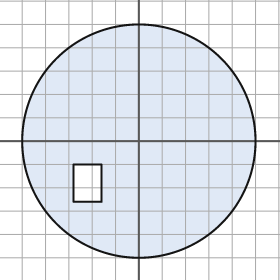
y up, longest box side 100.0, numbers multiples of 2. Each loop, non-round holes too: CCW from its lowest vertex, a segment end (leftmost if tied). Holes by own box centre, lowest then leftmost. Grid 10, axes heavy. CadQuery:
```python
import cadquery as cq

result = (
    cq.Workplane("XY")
    .moveTo(0.0, 0.0)
    .circle(50.0)
    .moveTo(-28.0, -26.0)
    .lineTo(-16.0, -26.0)
    .lineTo(-16.0, -10.0)
    .lineTo(-28.0, -10.0)
    .close()
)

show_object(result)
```